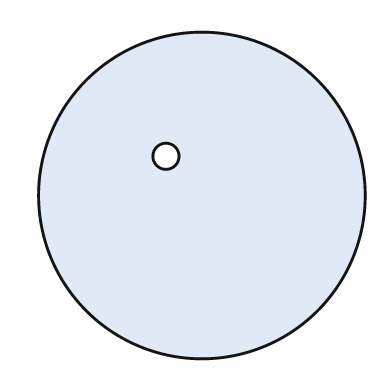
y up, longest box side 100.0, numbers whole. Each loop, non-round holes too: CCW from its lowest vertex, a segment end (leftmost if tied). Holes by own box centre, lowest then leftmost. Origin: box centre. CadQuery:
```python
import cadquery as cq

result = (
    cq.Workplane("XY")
    .moveTo(0.0, 0.0)
    .circle(50.0)
    .moveTo(-11.0, 12.0)
    .circle(4.0)
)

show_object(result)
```